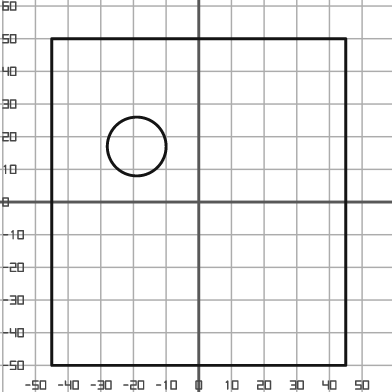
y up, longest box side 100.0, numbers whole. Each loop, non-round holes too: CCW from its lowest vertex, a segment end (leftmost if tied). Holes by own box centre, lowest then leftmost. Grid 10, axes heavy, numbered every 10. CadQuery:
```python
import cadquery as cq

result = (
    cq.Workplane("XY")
    .moveTo(-45.0, -50.0)
    .lineTo(45.0, -50.0)
    .lineTo(45.0, 50.0)
    .lineTo(-45.0, 50.0)
    .close()
    .moveTo(-19.0, 17.0)
    .circle(9.0)
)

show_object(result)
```